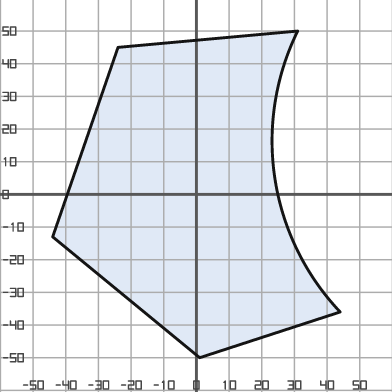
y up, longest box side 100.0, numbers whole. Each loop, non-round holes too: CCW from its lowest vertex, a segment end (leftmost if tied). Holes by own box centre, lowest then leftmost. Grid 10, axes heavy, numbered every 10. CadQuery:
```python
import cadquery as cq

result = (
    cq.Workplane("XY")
    .moveTo(1.0, -50.0)
    .lineTo(44.0, -36.0)
    .threePointArc((24.0, 5.0), (31.0, 50.0))
    .lineTo(-24.0, 45.0)
    .lineTo(-44.0, -13.0)
    .close()
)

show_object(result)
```